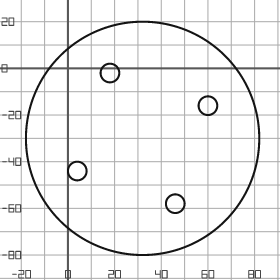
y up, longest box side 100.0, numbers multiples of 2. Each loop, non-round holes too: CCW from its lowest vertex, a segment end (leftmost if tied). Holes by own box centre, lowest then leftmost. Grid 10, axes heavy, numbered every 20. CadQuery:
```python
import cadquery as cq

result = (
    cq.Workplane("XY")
    .moveTo(32.0, -30.0)
    .circle(50.0)
    .moveTo(46.0, -58.0)
    .circle(4.0)
    .moveTo(4.0, -44.0)
    .circle(4.0)
    .moveTo(60.0, -16.0)
    .circle(4.0)
    .moveTo(18.0, -2.0)
    .circle(4.0)
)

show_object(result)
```